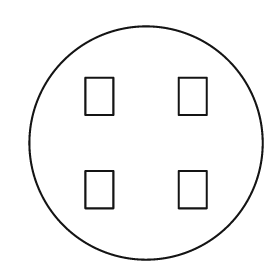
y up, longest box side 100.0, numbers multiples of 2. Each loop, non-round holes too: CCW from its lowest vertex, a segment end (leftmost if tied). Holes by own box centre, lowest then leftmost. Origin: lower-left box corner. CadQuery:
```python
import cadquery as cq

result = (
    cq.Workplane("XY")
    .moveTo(50.0, 50.0)
    .circle(50.0)
    .moveTo(24.0, 22.0)
    .lineTo(36.0, 22.0)
    .lineTo(36.0, 38.0)
    .lineTo(24.0, 38.0)
    .close()
    .moveTo(64.0, 22.0)
    .lineTo(76.0, 22.0)
    .lineTo(76.0, 38.0)
    .lineTo(64.0, 38.0)
    .close()
    .moveTo(24.0, 62.0)
    .lineTo(36.0, 62.0)
    .lineTo(36.0, 78.0)
    .lineTo(24.0, 78.0)
    .close()
    .moveTo(64.0, 62.0)
    .lineTo(76.0, 62.0)
    .lineTo(76.0, 78.0)
    .lineTo(64.0, 78.0)
    .close()
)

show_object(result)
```